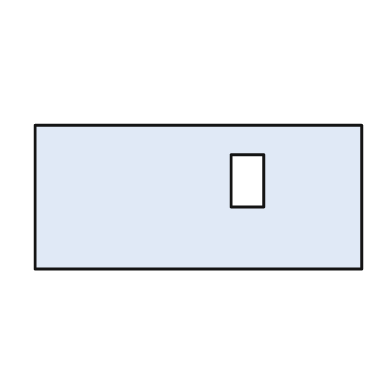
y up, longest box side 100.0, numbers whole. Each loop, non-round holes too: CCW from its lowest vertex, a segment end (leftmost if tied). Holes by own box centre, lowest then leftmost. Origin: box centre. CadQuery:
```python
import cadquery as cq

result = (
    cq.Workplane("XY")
    .moveTo(-50.0, -22.0)
    .lineTo(50.0, -22.0)
    .lineTo(50.0, 22.0)
    .lineTo(-50.0, 22.0)
    .close()
    .moveTo(10.0, -3.0)
    .lineTo(20.0, -3.0)
    .lineTo(20.0, 13.0)
    .lineTo(10.0, 13.0)
    .close()
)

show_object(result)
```